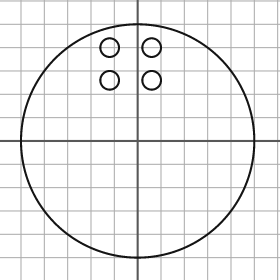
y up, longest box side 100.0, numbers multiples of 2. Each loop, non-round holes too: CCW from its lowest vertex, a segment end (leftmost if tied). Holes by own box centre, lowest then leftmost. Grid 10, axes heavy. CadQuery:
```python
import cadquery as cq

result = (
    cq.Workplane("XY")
    .moveTo(0.0, 0.0)
    .circle(50.0)
    .moveTo(-12.0, 26.0)
    .circle(4.0)
    .moveTo(6.0, 26.0)
    .circle(4.0)
    .moveTo(-12.0, 40.0)
    .circle(4.0)
    .moveTo(6.0, 40.0)
    .circle(4.0)
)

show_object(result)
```